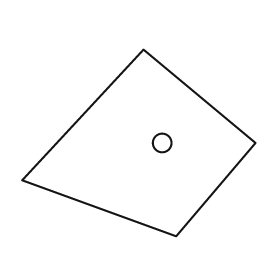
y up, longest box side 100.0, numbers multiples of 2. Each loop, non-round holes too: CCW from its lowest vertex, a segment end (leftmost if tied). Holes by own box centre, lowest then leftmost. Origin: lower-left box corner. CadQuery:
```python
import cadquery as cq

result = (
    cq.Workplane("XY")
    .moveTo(66.0, 0.0)
    .lineTo(100.0, 40.0)
    .lineTo(52.0, 80.0)
    .lineTo(0.0, 24.0)
    .close()
    .moveTo(60.0, 40.0)
    .circle(4.0)
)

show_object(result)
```